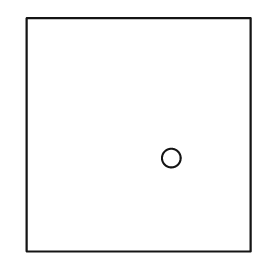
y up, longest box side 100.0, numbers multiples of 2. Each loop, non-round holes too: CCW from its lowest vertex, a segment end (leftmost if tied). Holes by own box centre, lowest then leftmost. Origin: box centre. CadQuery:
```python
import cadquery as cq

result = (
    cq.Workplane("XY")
    .moveTo(-48.0, -50.0)
    .lineTo(48.0, -50.0)
    .lineTo(48.0, 50.0)
    .lineTo(-48.0, 50.0)
    .close()
    .moveTo(14.0, -10.0)
    .circle(4.0)
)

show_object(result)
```